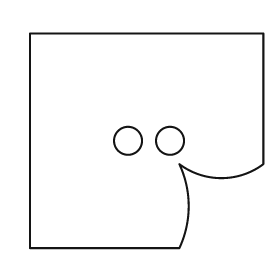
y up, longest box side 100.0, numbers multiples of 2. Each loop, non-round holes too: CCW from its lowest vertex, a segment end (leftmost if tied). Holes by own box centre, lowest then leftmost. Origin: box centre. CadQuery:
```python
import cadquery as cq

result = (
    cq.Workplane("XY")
    .moveTo(-50.0, -46.0)
    .lineTo(14.0, -46.0)
    .threePointArc((18.0, -28.0), (14.0, -10.0))
    .threePointArc((32.0, -16.0), (50.0, -10.0))
    .lineTo(50.0, 46.0)
    .lineTo(-50.0, 46.0)
    .close()
    .moveTo(-8.0, 0.0)
    .circle(6.0)
    .moveTo(10.0, 0.0)
    .circle(6.0)
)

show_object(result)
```